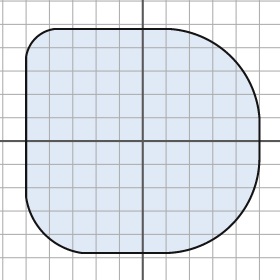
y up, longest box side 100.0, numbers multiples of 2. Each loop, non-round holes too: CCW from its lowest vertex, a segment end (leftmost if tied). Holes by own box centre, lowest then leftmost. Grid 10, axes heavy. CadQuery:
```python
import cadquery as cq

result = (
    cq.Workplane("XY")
    .moveTo(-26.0, -48.0)
    .lineTo(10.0, -48.0)
    .threePointArc((38.0, -36.0), (50.0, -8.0))
    .lineTo(50.0, 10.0)
    .threePointArc((38.0, 36.0), (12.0, 48.0))
    .lineTo(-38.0, 48.0)
    .threePointArc((-46.0, 44.0), (-50.0, 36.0))
    .lineTo(-50.0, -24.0)
    .threePointArc((-42.0, -40.0), (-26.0, -48.0))
    .close()
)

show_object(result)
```